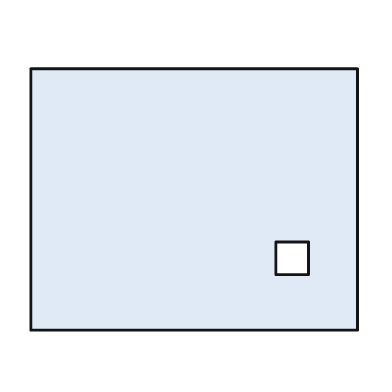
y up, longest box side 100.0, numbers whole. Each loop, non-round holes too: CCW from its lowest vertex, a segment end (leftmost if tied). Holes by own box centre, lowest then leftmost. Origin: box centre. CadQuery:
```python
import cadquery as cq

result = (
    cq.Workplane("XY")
    .moveTo(-50.0, -40.0)
    .lineTo(50.0, -40.0)
    .lineTo(50.0, 40.0)
    .lineTo(-50.0, 40.0)
    .close()
    .moveTo(25.0, -23.0)
    .lineTo(35.0, -23.0)
    .lineTo(35.0, -13.0)
    .lineTo(25.0, -13.0)
    .close()
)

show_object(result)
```